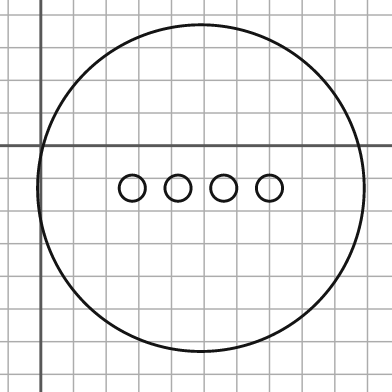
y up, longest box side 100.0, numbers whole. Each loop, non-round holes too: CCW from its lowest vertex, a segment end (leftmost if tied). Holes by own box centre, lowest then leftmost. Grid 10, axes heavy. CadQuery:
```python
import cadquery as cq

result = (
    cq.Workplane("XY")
    .moveTo(49.0, -13.0)
    .circle(50.0)
    .moveTo(28.0, -13.0)
    .circle(4.0)
    .moveTo(42.0, -13.0)
    .circle(4.0)
    .moveTo(56.0, -13.0)
    .circle(4.0)
    .moveTo(70.0, -13.0)
    .circle(4.0)
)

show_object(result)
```